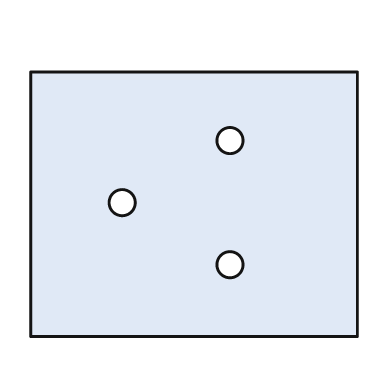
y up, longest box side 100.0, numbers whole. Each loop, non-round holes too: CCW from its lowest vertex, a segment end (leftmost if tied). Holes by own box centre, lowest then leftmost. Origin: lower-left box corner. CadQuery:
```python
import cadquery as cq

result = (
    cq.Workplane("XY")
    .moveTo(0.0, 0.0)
    .lineTo(100.0, 0.0)
    .lineTo(100.0, 81.0)
    .lineTo(0.0, 81.0)
    .close()
    .moveTo(61.0, 22.0)
    .circle(4.0)
    .moveTo(28.0, 41.0)
    .circle(4.0)
    .moveTo(61.0, 60.0)
    .circle(4.0)
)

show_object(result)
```